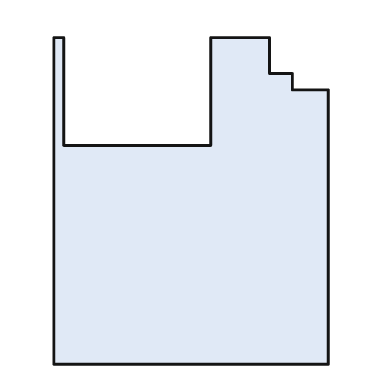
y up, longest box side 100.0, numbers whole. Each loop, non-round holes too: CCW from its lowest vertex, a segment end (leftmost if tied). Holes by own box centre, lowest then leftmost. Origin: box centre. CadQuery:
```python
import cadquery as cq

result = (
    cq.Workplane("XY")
    .moveTo(-42.0, -50.0)
    .lineTo(42.0, -50.0)
    .lineTo(42.0, 34.0)
    .lineTo(31.0, 34.0)
    .lineTo(31.0, 39.0)
    .lineTo(24.0, 39.0)
    .lineTo(24.0, 50.0)
    .lineTo(6.0, 50.0)
    .lineTo(6.0, 17.0)
    .lineTo(-39.0, 17.0)
    .lineTo(-39.0, 50.0)
    .lineTo(-42.0, 50.0)
    .close()
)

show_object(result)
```